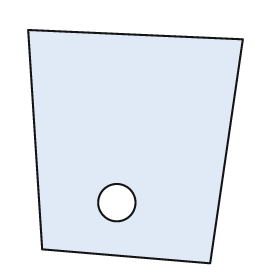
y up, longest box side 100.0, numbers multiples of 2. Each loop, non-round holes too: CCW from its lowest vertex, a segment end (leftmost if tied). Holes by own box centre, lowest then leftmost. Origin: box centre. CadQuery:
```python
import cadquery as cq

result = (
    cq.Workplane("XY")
    .moveTo(32.0, -50.0)
    .lineTo(46.0, 46.0)
    .lineTo(-46.0, 50.0)
    .lineTo(-40.0, -44.0)
    .close()
    .moveTo(-8.0, -24.0)
    .circle(8.0)
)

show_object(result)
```